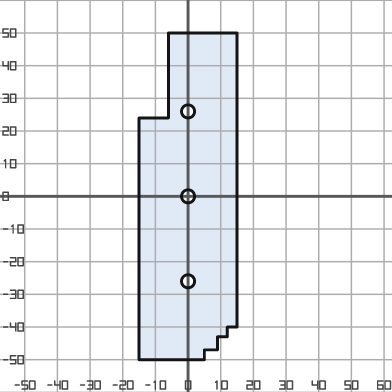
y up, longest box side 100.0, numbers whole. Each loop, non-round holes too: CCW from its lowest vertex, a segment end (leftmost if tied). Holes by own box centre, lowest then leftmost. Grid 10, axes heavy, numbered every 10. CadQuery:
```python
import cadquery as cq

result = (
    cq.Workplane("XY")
    .moveTo(-15.0, -50.0)
    .lineTo(5.0, -50.0)
    .lineTo(5.0, -47.0)
    .lineTo(9.0, -47.0)
    .lineTo(9.0, -43.0)
    .lineTo(12.0, -43.0)
    .lineTo(12.0, -40.0)
    .lineTo(15.0, -40.0)
    .lineTo(15.0, 50.0)
    .lineTo(-6.0, 50.0)
    .lineTo(-6.0, 24.0)
    .lineTo(-15.0, 24.0)
    .close()
    .moveTo(0.0, -26.0)
    .circle(2.0)
    .moveTo(0.0, 0.0)
    .circle(2.0)
    .moveTo(0.0, 26.0)
    .circle(2.0)
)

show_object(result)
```